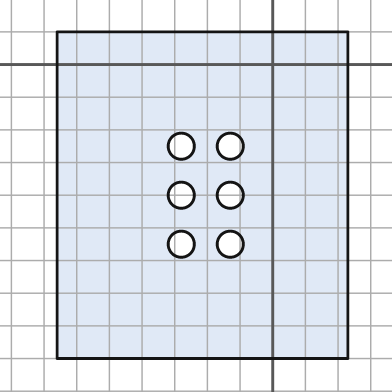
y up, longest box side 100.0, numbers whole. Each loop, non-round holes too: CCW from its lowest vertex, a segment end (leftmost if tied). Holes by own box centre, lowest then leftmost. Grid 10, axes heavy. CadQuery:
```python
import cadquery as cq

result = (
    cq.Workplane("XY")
    .moveTo(-66.0, -90.0)
    .lineTo(23.0, -90.0)
    .lineTo(23.0, 10.0)
    .lineTo(-66.0, 10.0)
    .close()
    .moveTo(-28.0, -55.0)
    .circle(4.0)
    .moveTo(-13.0, -55.0)
    .circle(4.0)
    .moveTo(-28.0, -40.0)
    .circle(4.0)
    .moveTo(-13.0, -40.0)
    .circle(4.0)
    .moveTo(-28.0, -25.0)
    .circle(4.0)
    .moveTo(-13.0, -25.0)
    .circle(4.0)
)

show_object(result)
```